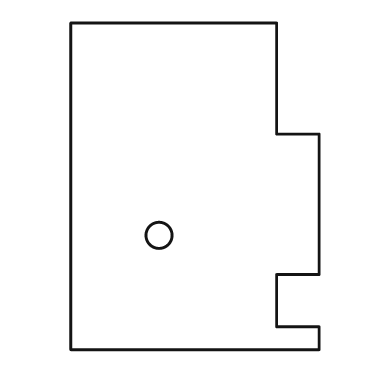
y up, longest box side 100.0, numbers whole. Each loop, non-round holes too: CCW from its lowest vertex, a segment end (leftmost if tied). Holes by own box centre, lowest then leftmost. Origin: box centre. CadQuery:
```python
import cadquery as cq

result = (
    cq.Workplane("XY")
    .moveTo(-38.0, -50.0)
    .lineTo(38.0, -50.0)
    .lineTo(38.0, -43.0)
    .lineTo(25.0, -43.0)
    .lineTo(25.0, -27.0)
    .lineTo(38.0, -27.0)
    .lineTo(38.0, 16.0)
    .lineTo(25.0, 16.0)
    .lineTo(25.0, 50.0)
    .lineTo(-38.0, 50.0)
    .close()
    .moveTo(-11.0, -15.0)
    .circle(4.0)
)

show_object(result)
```